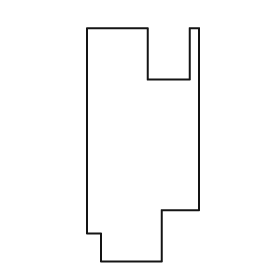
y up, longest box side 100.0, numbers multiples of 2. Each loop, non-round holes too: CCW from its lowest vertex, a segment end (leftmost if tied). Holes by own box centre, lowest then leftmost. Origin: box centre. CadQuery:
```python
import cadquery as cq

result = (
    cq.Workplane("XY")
    .moveTo(-18.0, -50.0)
    .lineTo(8.0, -50.0)
    .lineTo(8.0, -28.0)
    .lineTo(24.0, -28.0)
    .lineTo(24.0, 50.0)
    .lineTo(20.0, 50.0)
    .lineTo(20.0, 28.0)
    .lineTo(2.0, 28.0)
    .lineTo(2.0, 50.0)
    .lineTo(-24.0, 50.0)
    .lineTo(-24.0, -38.0)
    .lineTo(-18.0, -38.0)
    .close()
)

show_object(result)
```